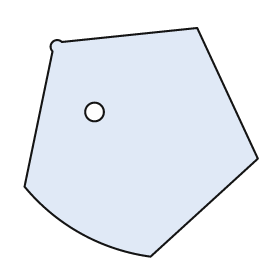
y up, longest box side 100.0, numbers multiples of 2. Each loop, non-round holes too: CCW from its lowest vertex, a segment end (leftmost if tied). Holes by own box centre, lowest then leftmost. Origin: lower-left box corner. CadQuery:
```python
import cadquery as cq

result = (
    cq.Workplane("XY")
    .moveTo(54.0, 0.0)
    .lineTo(100.0, 42.0)
    .lineTo(74.0, 98.0)
    .lineTo(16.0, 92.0)
    .threePointArc((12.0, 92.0), (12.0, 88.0))
    .lineTo(0.0, 30.0)
    .threePointArc((24.0, 10.0), (54.0, 0.0))
    .close()
    .moveTo(30.0, 62.0)
    .circle(4.0)
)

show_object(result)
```